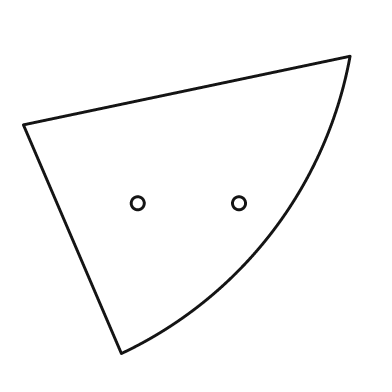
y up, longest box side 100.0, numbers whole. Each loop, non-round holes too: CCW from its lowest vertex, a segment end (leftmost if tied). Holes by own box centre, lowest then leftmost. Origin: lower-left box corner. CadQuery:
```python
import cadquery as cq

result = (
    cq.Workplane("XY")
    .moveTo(30.0, 0.0)
    .threePointArc((76.0, 37.0), (100.0, 91.0))
    .lineTo(0.0, 70.0)
    .close()
    .moveTo(35.0, 46.0)
    .circle(2.0)
    .moveTo(66.0, 46.0)
    .circle(2.0)
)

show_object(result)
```